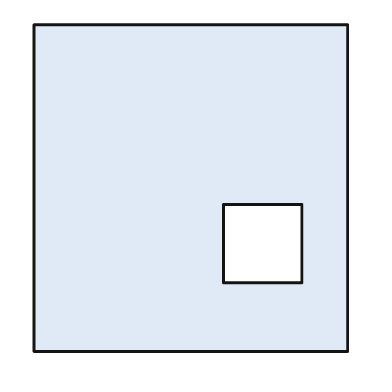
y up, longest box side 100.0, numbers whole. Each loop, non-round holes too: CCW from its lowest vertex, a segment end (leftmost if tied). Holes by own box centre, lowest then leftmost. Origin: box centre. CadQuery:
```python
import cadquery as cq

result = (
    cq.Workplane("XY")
    .moveTo(-48.0, -50.0)
    .lineTo(48.0, -50.0)
    .lineTo(48.0, 50.0)
    .lineTo(-48.0, 50.0)
    .close()
    .moveTo(10.0, -29.0)
    .lineTo(34.0, -29.0)
    .lineTo(34.0, -5.0)
    .lineTo(10.0, -5.0)
    .close()
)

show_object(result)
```